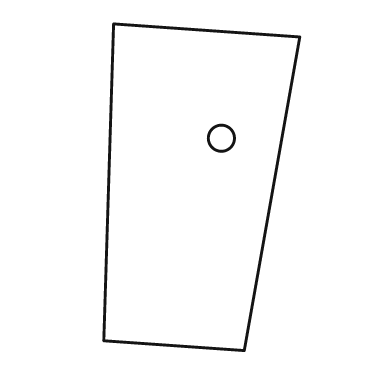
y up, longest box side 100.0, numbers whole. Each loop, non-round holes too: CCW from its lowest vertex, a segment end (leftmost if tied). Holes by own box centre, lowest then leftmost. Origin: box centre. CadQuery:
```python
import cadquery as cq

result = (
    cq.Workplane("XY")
    .moveTo(13.0, -50.0)
    .lineTo(30.0, 46.0)
    .lineTo(-27.0, 50.0)
    .lineTo(-30.0, -47.0)
    .close()
    .moveTo(6.0, 15.0)
    .circle(4.0)
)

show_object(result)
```